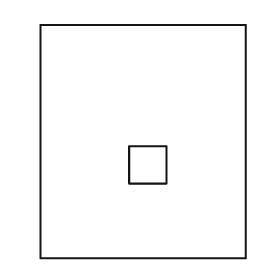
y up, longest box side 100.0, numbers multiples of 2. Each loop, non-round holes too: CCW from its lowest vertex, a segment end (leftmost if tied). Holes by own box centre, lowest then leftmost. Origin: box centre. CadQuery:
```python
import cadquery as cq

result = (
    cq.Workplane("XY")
    .moveTo(-44.0, -50.0)
    .lineTo(44.0, -50.0)
    .lineTo(44.0, 50.0)
    .lineTo(-44.0, 50.0)
    .close()
    .moveTo(-6.0, -18.0)
    .lineTo(10.0, -18.0)
    .lineTo(10.0, -2.0)
    .lineTo(-6.0, -2.0)
    .close()
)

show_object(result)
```